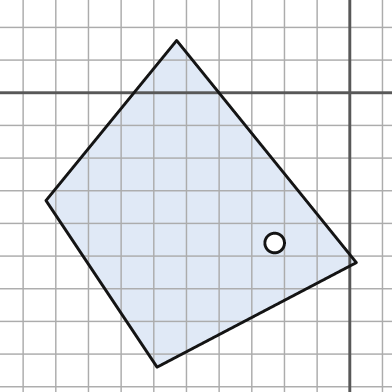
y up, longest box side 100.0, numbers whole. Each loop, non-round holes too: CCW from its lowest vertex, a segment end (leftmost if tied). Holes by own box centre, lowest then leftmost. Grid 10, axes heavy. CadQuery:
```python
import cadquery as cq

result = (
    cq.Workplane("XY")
    .moveTo(-59.0, -84.0)
    .lineTo(2.0, -52.0)
    .lineTo(-53.0, 16.0)
    .lineTo(-93.0, -33.0)
    .close()
    .moveTo(-23.0, -46.0)
    .circle(3.0)
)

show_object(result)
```